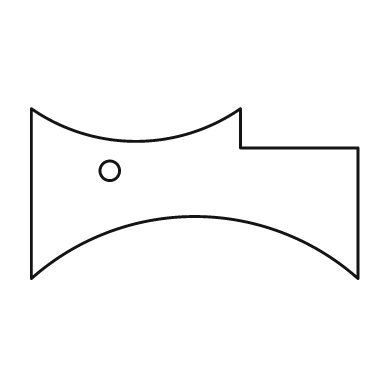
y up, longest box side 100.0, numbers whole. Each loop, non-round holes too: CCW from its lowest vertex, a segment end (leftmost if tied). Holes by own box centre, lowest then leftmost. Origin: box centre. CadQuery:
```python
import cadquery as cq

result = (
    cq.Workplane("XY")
    .moveTo(-50.0, -26.0)
    .threePointArc((0.0, -7.0), (50.0, -26.0))
    .lineTo(50.0, 14.0)
    .lineTo(14.0, 14.0)
    .lineTo(14.0, 26.0)
    .threePointArc((-18.0, 16.0), (-50.0, 26.0))
    .close()
    .moveTo(-26.0, 7.0)
    .circle(3.0)
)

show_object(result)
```